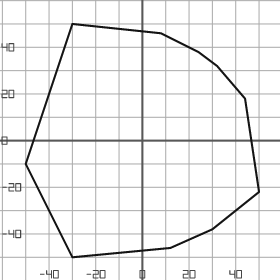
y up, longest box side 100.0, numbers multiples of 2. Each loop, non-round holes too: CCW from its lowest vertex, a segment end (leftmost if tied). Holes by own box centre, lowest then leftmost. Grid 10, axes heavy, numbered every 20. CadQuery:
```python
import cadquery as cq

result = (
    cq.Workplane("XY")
    .moveTo(-30.0, -50.0)
    .lineTo(12.0, -46.0)
    .lineTo(30.0, -38.0)
    .lineTo(50.0, -22.0)
    .lineTo(44.0, 18.0)
    .lineTo(32.0, 32.0)
    .lineTo(24.0, 38.0)
    .lineTo(8.0, 46.0)
    .lineTo(-30.0, 50.0)
    .lineTo(-50.0, -10.0)
    .close()
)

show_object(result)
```